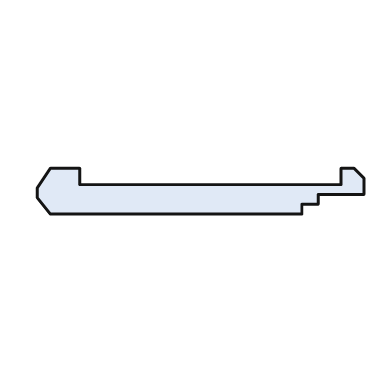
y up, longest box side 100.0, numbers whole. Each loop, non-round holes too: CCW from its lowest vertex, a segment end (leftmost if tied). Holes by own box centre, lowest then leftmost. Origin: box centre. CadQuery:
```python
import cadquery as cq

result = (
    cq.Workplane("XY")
    .moveTo(-46.0, -7.0)
    .lineTo(31.0, -7.0)
    .lineTo(31.0, -4.0)
    .lineTo(36.0, -4.0)
    .lineTo(36.0, -1.0)
    .lineTo(50.0, -1.0)
    .lineTo(50.0, 4.0)
    .lineTo(47.0, 7.0)
    .lineTo(43.0, 7.0)
    .lineTo(43.0, 2.0)
    .lineTo(-37.0, 2.0)
    .lineTo(-37.0, 7.0)
    .lineTo(-46.0, 7.0)
    .lineTo(-50.0, 1.0)
    .lineTo(-50.0, -2.0)
    .close()
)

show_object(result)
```